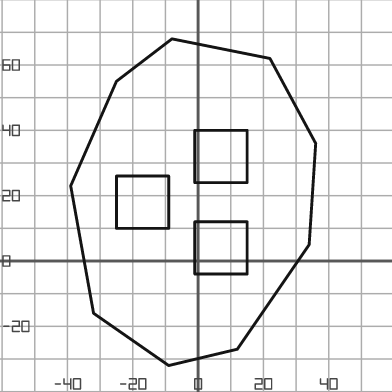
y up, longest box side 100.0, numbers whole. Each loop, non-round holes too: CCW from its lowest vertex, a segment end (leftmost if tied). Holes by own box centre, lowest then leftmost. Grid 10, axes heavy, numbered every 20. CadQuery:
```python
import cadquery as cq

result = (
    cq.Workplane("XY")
    .moveTo(-9.0, -32.0)
    .lineTo(12.0, -27.0)
    .lineTo(34.0, 5.0)
    .lineTo(36.0, 36.0)
    .lineTo(22.0, 62.0)
    .lineTo(-8.0, 68.0)
    .lineTo(-25.0, 55.0)
    .lineTo(-39.0, 23.0)
    .lineTo(-32.0, -16.0)
    .close()
    .moveTo(-1.0, -4.0)
    .lineTo(15.0, -4.0)
    .lineTo(15.0, 12.0)
    .lineTo(-1.0, 12.0)
    .close()
    .moveTo(-25.0, 10.0)
    .lineTo(-9.0, 10.0)
    .lineTo(-9.0, 26.0)
    .lineTo(-25.0, 26.0)
    .close()
    .moveTo(-1.0, 24.0)
    .lineTo(15.0, 24.0)
    .lineTo(15.0, 40.0)
    .lineTo(-1.0, 40.0)
    .close()
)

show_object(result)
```